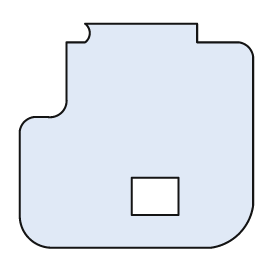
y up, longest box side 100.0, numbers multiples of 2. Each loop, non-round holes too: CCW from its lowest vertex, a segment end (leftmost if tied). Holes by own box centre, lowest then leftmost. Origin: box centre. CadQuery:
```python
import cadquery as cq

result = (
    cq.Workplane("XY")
    .moveTo(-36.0, -48.0)
    .lineTo(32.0, -48.0)
    .threePointArc((44.0, -42.0), (50.0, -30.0))
    .lineTo(50.0, 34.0)
    .threePointArc((48.0, 38.0), (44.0, 40.0))
    .lineTo(26.0, 40.0)
    .lineTo(26.0, 48.0)
    .lineTo(-22.0, 48.0)
    .threePointArc((-20.0, 44.0), (-22.0, 40.0))
    .lineTo(-30.0, 40.0)
    .lineTo(-30.0, 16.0)
    .threePointArc((-32.0, 10.0), (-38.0, 8.0))
    .lineTo(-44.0, 8.0)
    .threePointArc((-48.0, 6.0), (-50.0, 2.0))
    .lineTo(-50.0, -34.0)
    .threePointArc((-46.0, -44.0), (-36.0, -48.0))
    .close()
    .moveTo(-2.0, -34.0)
    .lineTo(18.0, -34.0)
    .lineTo(18.0, -18.0)
    .lineTo(-2.0, -18.0)
    .close()
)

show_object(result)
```